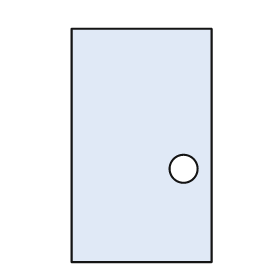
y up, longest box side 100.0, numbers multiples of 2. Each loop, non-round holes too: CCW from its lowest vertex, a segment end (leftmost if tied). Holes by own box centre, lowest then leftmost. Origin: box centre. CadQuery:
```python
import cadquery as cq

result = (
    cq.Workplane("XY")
    .moveTo(-30.0, -50.0)
    .lineTo(30.0, -50.0)
    .lineTo(30.0, 50.0)
    .lineTo(-30.0, 50.0)
    .close()
    .moveTo(18.0, -10.0)
    .circle(6.0)
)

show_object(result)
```